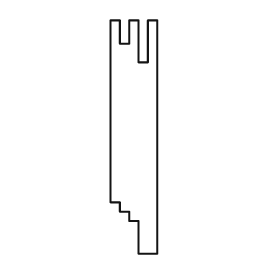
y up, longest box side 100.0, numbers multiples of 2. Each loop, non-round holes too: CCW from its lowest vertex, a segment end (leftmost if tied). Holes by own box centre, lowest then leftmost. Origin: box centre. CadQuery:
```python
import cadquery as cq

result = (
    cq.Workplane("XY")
    .moveTo(2.0, -50.0)
    .lineTo(10.0, -50.0)
    .lineTo(10.0, 50.0)
    .lineTo(6.0, 50.0)
    .lineTo(6.0, 32.0)
    .lineTo(2.0, 32.0)
    .lineTo(2.0, 50.0)
    .lineTo(-2.0, 50.0)
    .lineTo(-2.0, 40.0)
    .lineTo(-6.0, 40.0)
    .lineTo(-6.0, 50.0)
    .lineTo(-10.0, 50.0)
    .lineTo(-10.0, -28.0)
    .lineTo(-6.0, -28.0)
    .lineTo(-6.0, -32.0)
    .lineTo(-2.0, -32.0)
    .lineTo(-2.0, -36.0)
    .lineTo(2.0, -36.0)
    .close()
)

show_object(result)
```